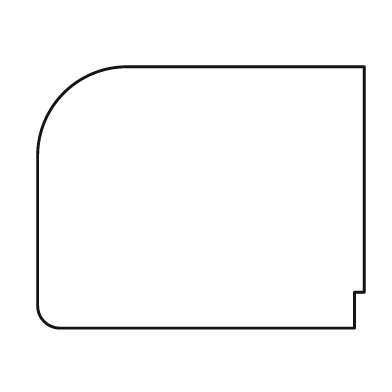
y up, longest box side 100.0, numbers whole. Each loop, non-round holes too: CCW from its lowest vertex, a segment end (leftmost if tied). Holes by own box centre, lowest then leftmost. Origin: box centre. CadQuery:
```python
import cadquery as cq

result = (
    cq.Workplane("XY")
    .moveTo(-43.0, -40.0)
    .lineTo(47.0, -40.0)
    .lineTo(47.0, -29.0)
    .lineTo(50.0, -29.0)
    .lineTo(50.0, 40.0)
    .lineTo(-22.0, 40.0)
    .threePointArc((-42.0, 32.0), (-50.0, 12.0))
    .lineTo(-50.0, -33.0)
    .threePointArc((-48.0, -38.0), (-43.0, -40.0))
    .close()
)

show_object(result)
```